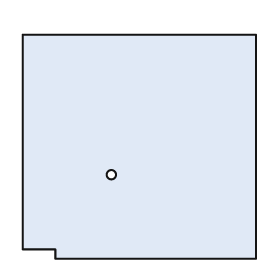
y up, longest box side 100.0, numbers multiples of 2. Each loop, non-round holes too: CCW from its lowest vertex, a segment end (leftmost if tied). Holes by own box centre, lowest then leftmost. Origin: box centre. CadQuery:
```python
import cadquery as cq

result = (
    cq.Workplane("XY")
    .moveTo(-36.0, -48.0)
    .lineTo(50.0, -48.0)
    .lineTo(50.0, 48.0)
    .lineTo(-50.0, 48.0)
    .lineTo(-50.0, -44.0)
    .lineTo(-36.0, -44.0)
    .close()
    .moveTo(-12.0, -12.0)
    .circle(2.0)
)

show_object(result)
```